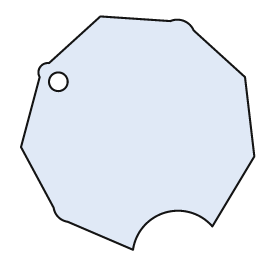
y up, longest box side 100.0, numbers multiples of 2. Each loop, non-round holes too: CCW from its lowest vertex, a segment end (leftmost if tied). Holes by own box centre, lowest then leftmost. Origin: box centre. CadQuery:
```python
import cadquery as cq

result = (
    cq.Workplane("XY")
    .moveTo(-2.0, -50.0)
    .threePointArc((12.0, -34.0), (32.0, -40.0))
    .lineTo(50.0, -10.0)
    .lineTo(46.0, 24.0)
    .lineTo(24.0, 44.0)
    .threePointArc((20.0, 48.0), (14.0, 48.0))
    .lineTo(-16.0, 50.0)
    .lineTo(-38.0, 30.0)
    .threePointArc((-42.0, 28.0), (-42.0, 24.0))
    .lineTo(-50.0, -6.0)
    .lineTo(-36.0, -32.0)
    .threePointArc((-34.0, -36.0), (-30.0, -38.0))
    .close()
    .moveTo(-34.0, 22.0)
    .circle(4.0)
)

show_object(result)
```